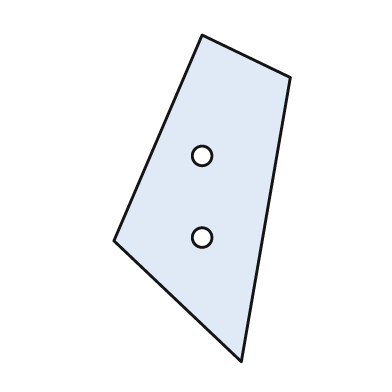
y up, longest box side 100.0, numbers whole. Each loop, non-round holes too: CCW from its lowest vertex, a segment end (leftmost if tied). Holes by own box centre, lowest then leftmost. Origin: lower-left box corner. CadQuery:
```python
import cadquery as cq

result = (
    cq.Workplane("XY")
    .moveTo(39.0, 0.0)
    .lineTo(54.0, 87.0)
    .lineTo(27.0, 100.0)
    .lineTo(0.0, 37.0)
    .close()
    .moveTo(27.0, 38.0)
    .circle(3.0)
    .moveTo(27.0, 63.0)
    .circle(3.0)
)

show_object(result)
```